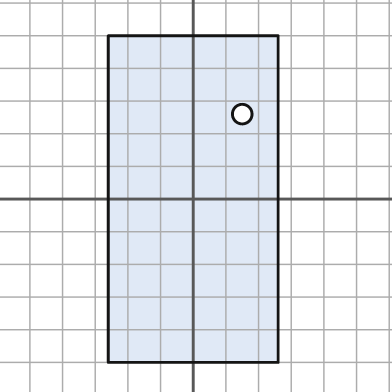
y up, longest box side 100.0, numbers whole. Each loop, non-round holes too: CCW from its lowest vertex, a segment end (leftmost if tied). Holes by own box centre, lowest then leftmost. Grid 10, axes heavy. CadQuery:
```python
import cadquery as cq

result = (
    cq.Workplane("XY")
    .moveTo(-26.0, -50.0)
    .lineTo(26.0, -50.0)
    .lineTo(26.0, 50.0)
    .lineTo(-26.0, 50.0)
    .close()
    .moveTo(15.0, 26.0)
    .circle(3.0)
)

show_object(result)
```